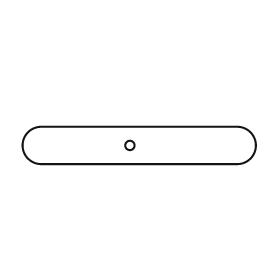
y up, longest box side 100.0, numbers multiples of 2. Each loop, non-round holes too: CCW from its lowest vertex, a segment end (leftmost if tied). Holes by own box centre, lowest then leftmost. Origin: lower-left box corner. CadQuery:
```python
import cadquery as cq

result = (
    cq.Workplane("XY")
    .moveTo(8.0, 0.0)
    .lineTo(92.0, 0.0)
    .threePointArc((100.0, 8.0), (92.0, 16.0))
    .lineTo(8.0, 16.0)
    .threePointArc((0.0, 8.0), (8.0, 0.0))
    .close()
    .moveTo(46.0, 8.0)
    .circle(2.0)
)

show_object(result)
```